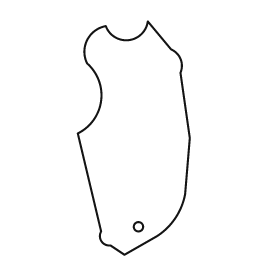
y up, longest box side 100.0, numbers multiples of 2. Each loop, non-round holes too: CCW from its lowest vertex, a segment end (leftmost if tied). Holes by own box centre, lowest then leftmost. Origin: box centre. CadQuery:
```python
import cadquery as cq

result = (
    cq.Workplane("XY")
    .moveTo(-4.0, -50.0)
    .lineTo(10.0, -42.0)
    .threePointArc((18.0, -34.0), (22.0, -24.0))
    .lineTo(24.0, 0.0)
    .lineTo(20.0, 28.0)
    .threePointArc((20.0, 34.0), (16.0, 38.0))
    .lineTo(6.0, 50.0)
    .threePointArc((-2.0, 42.0), (-12.0, 48.0))
    .threePointArc((-20.0, 42.0), (-20.0, 32.0))
    .threePointArc((-14.0, 16.0), (-24.0, 2.0))
    .lineTo(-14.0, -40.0)
    .threePointArc((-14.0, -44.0), (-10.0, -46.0))
    .close()
    .moveTo(2.0, -38.0)
    .circle(2.0)
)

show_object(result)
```